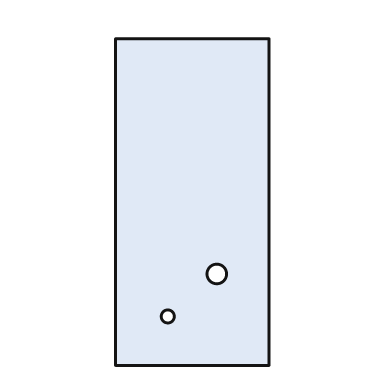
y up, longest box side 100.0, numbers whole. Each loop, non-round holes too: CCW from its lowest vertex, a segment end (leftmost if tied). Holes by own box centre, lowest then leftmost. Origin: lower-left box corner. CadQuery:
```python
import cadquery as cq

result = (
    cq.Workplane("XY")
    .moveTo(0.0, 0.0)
    .lineTo(47.0, 0.0)
    .lineTo(47.0, 100.0)
    .lineTo(0.0, 100.0)
    .close()
    .moveTo(16.0, 15.0)
    .circle(2.0)
    .moveTo(31.0, 28.0)
    .circle(3.0)
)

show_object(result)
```